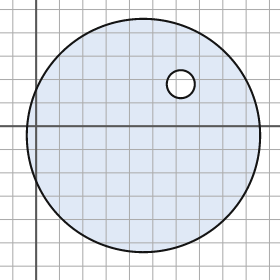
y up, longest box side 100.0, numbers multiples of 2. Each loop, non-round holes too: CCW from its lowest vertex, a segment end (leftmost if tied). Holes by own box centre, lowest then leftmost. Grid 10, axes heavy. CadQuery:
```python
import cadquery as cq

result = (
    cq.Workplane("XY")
    .moveTo(46.0, -4.0)
    .circle(50.0)
    .moveTo(62.0, 18.0)
    .circle(6.0)
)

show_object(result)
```